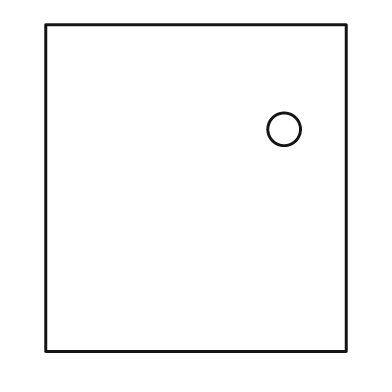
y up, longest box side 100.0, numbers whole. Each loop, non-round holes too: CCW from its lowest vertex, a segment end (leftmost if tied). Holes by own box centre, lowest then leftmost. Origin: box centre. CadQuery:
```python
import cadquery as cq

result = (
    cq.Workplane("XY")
    .moveTo(-46.0, -50.0)
    .lineTo(46.0, -50.0)
    .lineTo(46.0, 50.0)
    .lineTo(-46.0, 50.0)
    .close()
    .moveTo(27.0, 18.0)
    .circle(5.0)
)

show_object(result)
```